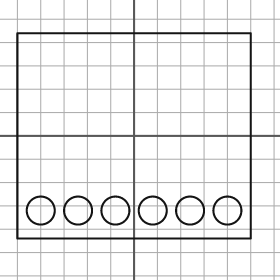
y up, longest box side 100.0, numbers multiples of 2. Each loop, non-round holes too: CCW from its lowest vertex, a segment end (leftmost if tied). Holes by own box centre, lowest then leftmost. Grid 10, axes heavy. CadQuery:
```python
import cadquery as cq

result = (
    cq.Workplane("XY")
    .moveTo(-50.0, -44.0)
    .lineTo(50.0, -44.0)
    .lineTo(50.0, 44.0)
    .lineTo(-50.0, 44.0)
    .close()
    .moveTo(-40.0, -32.0)
    .circle(6.0)
    .moveTo(-24.0, -32.0)
    .circle(6.0)
    .moveTo(-8.0, -32.0)
    .circle(6.0)
    .moveTo(8.0, -32.0)
    .circle(6.0)
    .moveTo(24.0, -32.0)
    .circle(6.0)
    .moveTo(40.0, -32.0)
    .circle(6.0)
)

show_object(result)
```